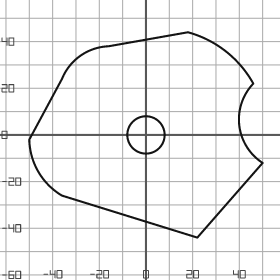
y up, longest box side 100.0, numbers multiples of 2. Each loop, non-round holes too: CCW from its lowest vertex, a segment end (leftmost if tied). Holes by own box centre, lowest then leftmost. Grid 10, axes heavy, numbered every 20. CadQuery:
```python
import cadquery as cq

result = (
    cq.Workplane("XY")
    .moveTo(22.0, -44.0)
    .lineTo(50.0, -12.0)
    .threePointArc((40.0, 4.0), (46.0, 22.0))
    .threePointArc((34.0, 36.0), (18.0, 44.0))
    .lineTo(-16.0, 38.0)
    .threePointArc((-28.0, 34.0), (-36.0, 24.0))
    .lineTo(-50.0, -2.0)
    .threePointArc((-46.0, -16.0), (-36.0, -26.0))
    .close()
    .moveTo(0.0, 0.0)
    .circle(8.0)
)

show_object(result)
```